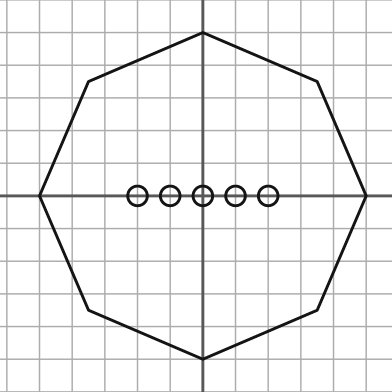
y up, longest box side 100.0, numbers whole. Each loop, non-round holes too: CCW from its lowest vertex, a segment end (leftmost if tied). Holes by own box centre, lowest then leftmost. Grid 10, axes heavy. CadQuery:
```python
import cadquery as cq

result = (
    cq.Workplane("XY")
    .moveTo(0.0, -50.0)
    .lineTo(35.0, -35.0)
    .lineTo(50.0, 0.0)
    .lineTo(35.0, 35.0)
    .lineTo(0.0, 50.0)
    .lineTo(-35.0, 35.0)
    .lineTo(-50.0, 0.0)
    .lineTo(-35.0, -35.0)
    .close()
    .moveTo(-20.0, 0.0)
    .circle(3.0)
    .moveTo(-10.0, 0.0)
    .circle(3.0)
    .moveTo(0.0, 0.0)
    .circle(3.0)
    .moveTo(10.0, 0.0)
    .circle(3.0)
    .moveTo(20.0, 0.0)
    .circle(3.0)
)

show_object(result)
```